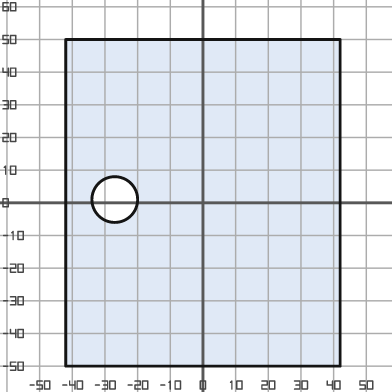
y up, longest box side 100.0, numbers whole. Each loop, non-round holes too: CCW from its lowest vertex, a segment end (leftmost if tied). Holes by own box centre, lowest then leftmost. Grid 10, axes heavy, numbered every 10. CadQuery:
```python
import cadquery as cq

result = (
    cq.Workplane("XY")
    .moveTo(-42.0, -50.0)
    .lineTo(42.0, -50.0)
    .lineTo(42.0, 50.0)
    .lineTo(-42.0, 50.0)
    .close()
    .moveTo(-27.0, 1.0)
    .circle(7.0)
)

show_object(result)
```